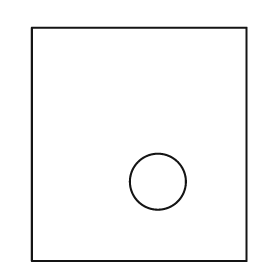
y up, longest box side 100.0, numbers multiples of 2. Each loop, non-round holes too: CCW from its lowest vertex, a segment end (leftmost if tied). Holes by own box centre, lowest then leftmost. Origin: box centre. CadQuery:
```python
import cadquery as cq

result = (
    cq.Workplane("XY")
    .moveTo(-46.0, -50.0)
    .lineTo(46.0, -50.0)
    .lineTo(46.0, 50.0)
    .lineTo(-46.0, 50.0)
    .close()
    .moveTo(8.0, -16.0)
    .circle(12.0)
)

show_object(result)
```